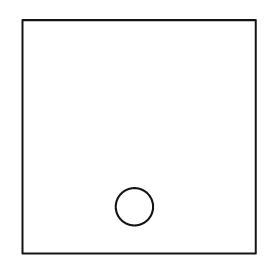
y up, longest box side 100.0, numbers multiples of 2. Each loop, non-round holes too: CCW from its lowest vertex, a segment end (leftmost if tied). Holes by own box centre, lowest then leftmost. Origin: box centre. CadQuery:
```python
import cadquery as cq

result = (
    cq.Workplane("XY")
    .moveTo(-50.0, -50.0)
    .lineTo(50.0, -50.0)
    .lineTo(50.0, 50.0)
    .lineTo(-50.0, 50.0)
    .close()
    .moveTo(-2.0, -30.0)
    .circle(8.0)
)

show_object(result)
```